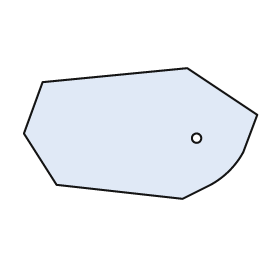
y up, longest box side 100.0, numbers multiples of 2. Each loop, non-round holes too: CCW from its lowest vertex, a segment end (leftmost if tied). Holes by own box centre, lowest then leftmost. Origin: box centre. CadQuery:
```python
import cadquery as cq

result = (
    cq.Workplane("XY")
    .moveTo(18.0, -28.0)
    .lineTo(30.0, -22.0)
    .threePointArc((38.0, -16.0), (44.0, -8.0))
    .lineTo(50.0, 8.0)
    .lineTo(20.0, 28.0)
    .lineTo(-42.0, 22.0)
    .lineTo(-50.0, 0.0)
    .lineTo(-36.0, -22.0)
    .close()
    .moveTo(24.0, -2.0)
    .circle(2.0)
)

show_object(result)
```